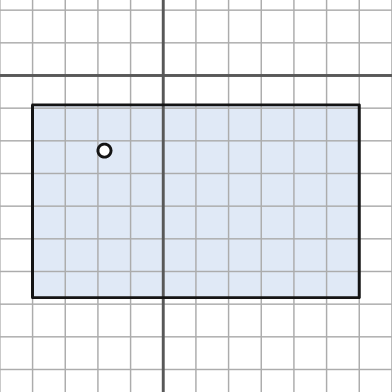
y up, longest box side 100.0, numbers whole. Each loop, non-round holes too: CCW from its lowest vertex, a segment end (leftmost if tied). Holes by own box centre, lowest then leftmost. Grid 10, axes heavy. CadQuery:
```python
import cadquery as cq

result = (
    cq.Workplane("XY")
    .moveTo(-40.0, -68.0)
    .lineTo(60.0, -68.0)
    .lineTo(60.0, -9.0)
    .lineTo(-40.0, -9.0)
    .close()
    .moveTo(-18.0, -23.0)
    .circle(2.0)
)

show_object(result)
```